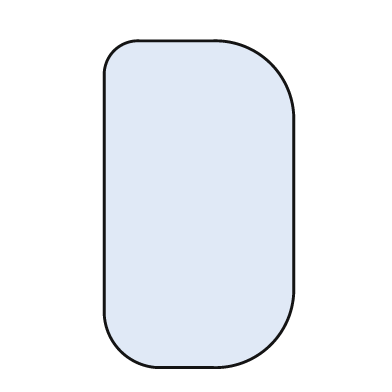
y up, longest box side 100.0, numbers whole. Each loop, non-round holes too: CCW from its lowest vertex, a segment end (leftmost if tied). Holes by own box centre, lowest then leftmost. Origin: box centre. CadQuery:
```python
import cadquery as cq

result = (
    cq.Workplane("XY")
    .moveTo(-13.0, -50.0)
    .lineTo(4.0, -50.0)
    .threePointArc((22.0, -43.0), (29.0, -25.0))
    .lineTo(29.0, 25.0)
    .threePointArc((22.0, 43.0), (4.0, 50.0))
    .lineTo(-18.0, 50.0)
    .threePointArc((-26.0, 47.0), (-29.0, 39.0))
    .lineTo(-29.0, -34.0)
    .threePointArc((-24.0, -45.0), (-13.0, -50.0))
    .close()
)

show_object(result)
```